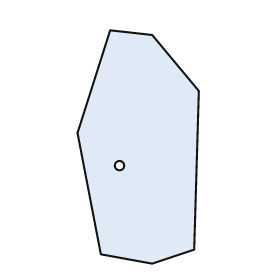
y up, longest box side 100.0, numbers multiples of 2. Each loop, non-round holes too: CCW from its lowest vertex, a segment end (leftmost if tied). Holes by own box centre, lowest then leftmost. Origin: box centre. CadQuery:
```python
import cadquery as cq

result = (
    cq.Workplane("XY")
    .moveTo(6.0, -50.0)
    .lineTo(24.0, -44.0)
    .lineTo(26.0, 24.0)
    .lineTo(6.0, 48.0)
    .lineTo(-12.0, 50.0)
    .lineTo(-26.0, 6.0)
    .lineTo(-16.0, -46.0)
    .close()
    .moveTo(-8.0, -8.0)
    .circle(2.0)
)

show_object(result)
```